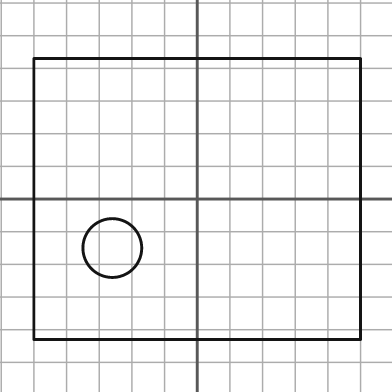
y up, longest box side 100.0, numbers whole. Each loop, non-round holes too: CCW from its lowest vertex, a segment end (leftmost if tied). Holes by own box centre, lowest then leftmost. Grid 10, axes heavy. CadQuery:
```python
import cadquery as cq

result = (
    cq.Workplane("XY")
    .moveTo(-50.0, -43.0)
    .lineTo(50.0, -43.0)
    .lineTo(50.0, 43.0)
    .lineTo(-50.0, 43.0)
    .close()
    .moveTo(-26.0, -15.0)
    .circle(9.0)
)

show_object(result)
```